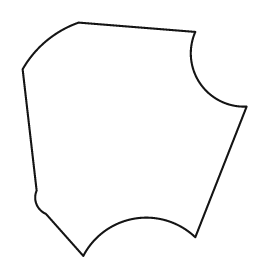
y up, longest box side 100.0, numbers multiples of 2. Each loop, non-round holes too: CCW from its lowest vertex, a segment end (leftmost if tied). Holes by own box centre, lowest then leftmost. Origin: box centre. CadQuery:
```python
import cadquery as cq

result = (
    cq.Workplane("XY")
    .moveTo(-22.0, -50.0)
    .threePointArc((0.0, -34.0), (26.0, -42.0))
    .lineTo(48.0, 14.0)
    .threePointArc((28.0, 24.0), (26.0, 46.0))
    .lineTo(-24.0, 50.0)
    .threePointArc((-38.0, 42.0), (-48.0, 30.0))
    .lineTo(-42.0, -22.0)
    .threePointArc((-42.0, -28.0), (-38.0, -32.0))
    .close()
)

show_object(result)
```